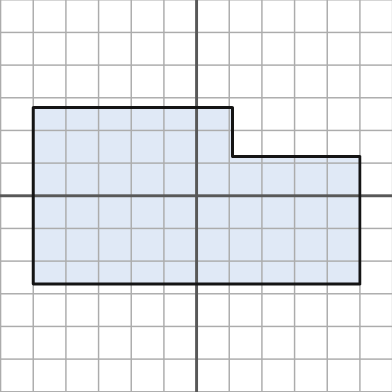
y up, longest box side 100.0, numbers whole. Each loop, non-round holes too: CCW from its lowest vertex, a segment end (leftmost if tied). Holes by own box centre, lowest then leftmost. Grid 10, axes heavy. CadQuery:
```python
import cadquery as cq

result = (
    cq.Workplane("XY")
    .moveTo(-50.0, -27.0)
    .lineTo(50.0, -27.0)
    .lineTo(50.0, 12.0)
    .lineTo(11.0, 12.0)
    .lineTo(11.0, 27.0)
    .lineTo(-50.0, 27.0)
    .close()
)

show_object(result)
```